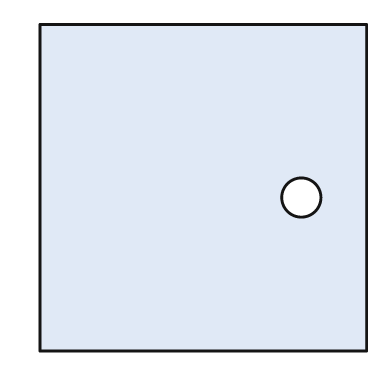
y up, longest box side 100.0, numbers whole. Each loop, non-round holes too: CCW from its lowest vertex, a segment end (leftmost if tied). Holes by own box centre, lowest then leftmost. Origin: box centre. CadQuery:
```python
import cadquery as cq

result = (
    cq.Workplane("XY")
    .moveTo(-50.0, -50.0)
    .lineTo(50.0, -50.0)
    .lineTo(50.0, 50.0)
    .lineTo(-50.0, 50.0)
    .close()
    .moveTo(30.0, -3.0)
    .circle(6.0)
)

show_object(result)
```